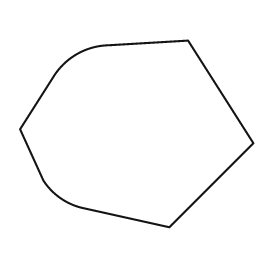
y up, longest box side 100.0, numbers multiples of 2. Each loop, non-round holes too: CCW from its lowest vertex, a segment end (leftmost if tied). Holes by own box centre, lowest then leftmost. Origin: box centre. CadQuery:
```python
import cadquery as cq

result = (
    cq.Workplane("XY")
    .moveTo(14.0, -40.0)
    .lineTo(50.0, -4.0)
    .lineTo(22.0, 40.0)
    .lineTo(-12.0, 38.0)
    .threePointArc((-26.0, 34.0), (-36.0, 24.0))
    .lineTo(-50.0, 2.0)
    .lineTo(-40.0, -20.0)
    .threePointArc((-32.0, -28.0), (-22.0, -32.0))
    .close()
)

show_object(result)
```